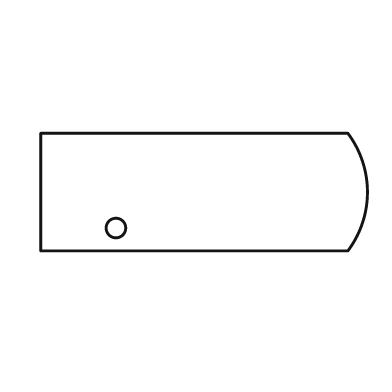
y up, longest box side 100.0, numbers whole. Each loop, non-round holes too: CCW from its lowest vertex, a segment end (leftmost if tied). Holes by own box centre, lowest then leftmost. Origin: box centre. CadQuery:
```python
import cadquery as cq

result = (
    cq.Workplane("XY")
    .moveTo(-50.0, -18.0)
    .lineTo(44.0, -18.0)
    .threePointArc((50.0, 0.0), (44.0, 18.0))
    .lineTo(-50.0, 18.0)
    .close()
    .moveTo(-27.0, -11.0)
    .circle(3.0)
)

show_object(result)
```